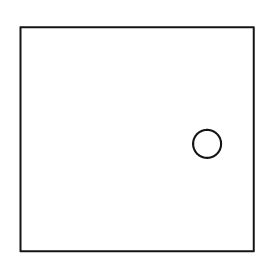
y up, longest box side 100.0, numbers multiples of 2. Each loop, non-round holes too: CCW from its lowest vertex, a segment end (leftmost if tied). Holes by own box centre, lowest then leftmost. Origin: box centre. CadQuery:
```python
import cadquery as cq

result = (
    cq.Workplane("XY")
    .moveTo(-50.0, -48.0)
    .lineTo(50.0, -48.0)
    .lineTo(50.0, 48.0)
    .lineTo(-50.0, 48.0)
    .close()
    .moveTo(30.0, -2.0)
    .circle(6.0)
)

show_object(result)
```